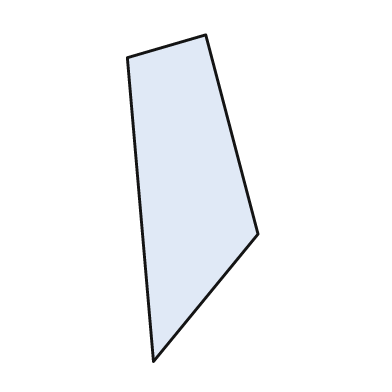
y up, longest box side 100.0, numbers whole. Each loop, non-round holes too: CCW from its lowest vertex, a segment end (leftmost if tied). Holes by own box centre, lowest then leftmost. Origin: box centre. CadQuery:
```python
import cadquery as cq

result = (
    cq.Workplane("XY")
    .moveTo(-12.0, -50.0)
    .lineTo(20.0, -11.0)
    .lineTo(4.0, 50.0)
    .lineTo(-20.0, 43.0)
    .close()
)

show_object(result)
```